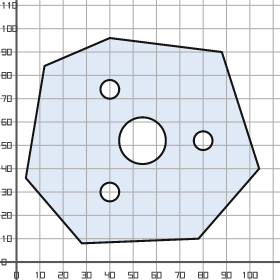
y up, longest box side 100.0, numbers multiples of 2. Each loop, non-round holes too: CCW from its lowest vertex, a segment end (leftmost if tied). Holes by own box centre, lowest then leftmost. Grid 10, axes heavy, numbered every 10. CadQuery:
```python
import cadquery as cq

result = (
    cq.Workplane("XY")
    .moveTo(28.0, 8.0)
    .lineTo(78.0, 10.0)
    .lineTo(104.0, 40.0)
    .lineTo(88.0, 90.0)
    .lineTo(40.0, 96.0)
    .lineTo(12.0, 84.0)
    .lineTo(4.0, 36.0)
    .close()
    .moveTo(40.0, 30.0)
    .circle(4.0)
    .moveTo(54.0, 52.0)
    .circle(10.0)
    .moveTo(80.0, 52.0)
    .circle(4.0)
    .moveTo(40.0, 74.0)
    .circle(4.0)
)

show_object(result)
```